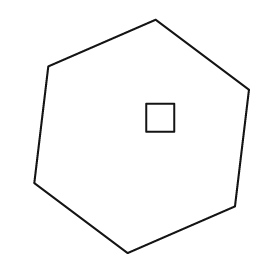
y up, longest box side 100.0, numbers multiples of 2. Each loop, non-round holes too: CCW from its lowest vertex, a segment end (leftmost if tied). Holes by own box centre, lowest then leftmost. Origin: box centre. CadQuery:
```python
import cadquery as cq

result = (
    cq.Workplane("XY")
    .moveTo(-6.0, -50.0)
    .lineTo(40.0, -30.0)
    .lineTo(46.0, 20.0)
    .lineTo(6.0, 50.0)
    .lineTo(-40.0, 30.0)
    .lineTo(-46.0, -20.0)
    .close()
    .moveTo(2.0, 2.0)
    .lineTo(14.0, 2.0)
    .lineTo(14.0, 14.0)
    .lineTo(2.0, 14.0)
    .close()
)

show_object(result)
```